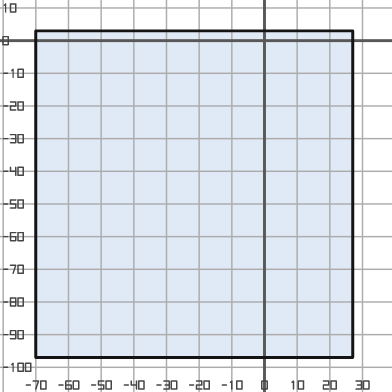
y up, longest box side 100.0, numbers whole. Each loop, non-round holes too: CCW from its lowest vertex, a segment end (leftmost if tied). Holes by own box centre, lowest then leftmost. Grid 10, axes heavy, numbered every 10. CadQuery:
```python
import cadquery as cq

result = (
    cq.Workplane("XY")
    .moveTo(-70.0, -97.0)
    .lineTo(27.0, -97.0)
    .lineTo(27.0, 3.0)
    .lineTo(-70.0, 3.0)
    .close()
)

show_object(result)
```